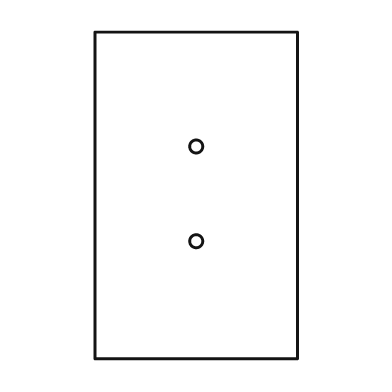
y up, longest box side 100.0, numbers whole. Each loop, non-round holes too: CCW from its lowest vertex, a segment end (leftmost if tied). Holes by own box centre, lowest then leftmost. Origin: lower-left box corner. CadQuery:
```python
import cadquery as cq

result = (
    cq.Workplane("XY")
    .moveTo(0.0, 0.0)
    .lineTo(62.0, 0.0)
    .lineTo(62.0, 100.0)
    .lineTo(0.0, 100.0)
    .close()
    .moveTo(31.0, 36.0)
    .circle(2.0)
    .moveTo(31.0, 65.0)
    .circle(2.0)
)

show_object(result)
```